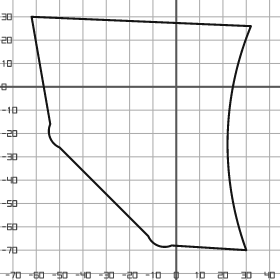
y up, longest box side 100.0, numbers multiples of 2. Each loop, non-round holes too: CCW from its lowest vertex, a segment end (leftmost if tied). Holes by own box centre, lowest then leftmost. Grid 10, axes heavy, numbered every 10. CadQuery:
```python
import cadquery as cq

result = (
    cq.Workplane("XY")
    .moveTo(30.0, -70.0)
    .threePointArc((22.0, -22.0), (32.0, 26.0))
    .lineTo(-62.0, 30.0)
    .lineTo(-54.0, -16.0)
    .threePointArc((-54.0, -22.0), (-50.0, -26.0))
    .lineTo(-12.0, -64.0)
    .threePointArc((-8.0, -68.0), (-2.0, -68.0))
    .close()
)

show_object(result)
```